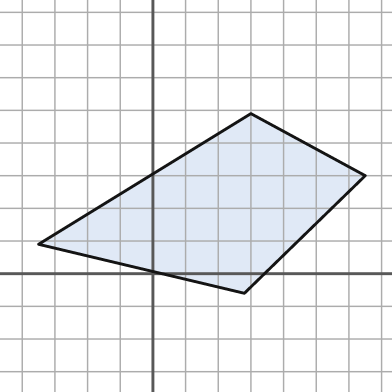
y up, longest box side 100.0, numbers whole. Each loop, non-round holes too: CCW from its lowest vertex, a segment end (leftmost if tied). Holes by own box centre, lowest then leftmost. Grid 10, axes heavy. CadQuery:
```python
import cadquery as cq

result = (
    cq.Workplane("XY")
    .moveTo(28.0, -6.0)
    .lineTo(65.0, 30.0)
    .lineTo(30.0, 49.0)
    .lineTo(-35.0, 9.0)
    .close()
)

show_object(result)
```